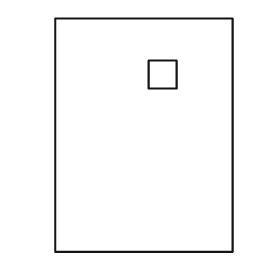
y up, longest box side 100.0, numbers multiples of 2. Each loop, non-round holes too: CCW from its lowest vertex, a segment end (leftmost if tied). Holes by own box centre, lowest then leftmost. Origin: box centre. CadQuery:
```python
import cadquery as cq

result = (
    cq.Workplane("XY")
    .moveTo(-38.0, -50.0)
    .lineTo(38.0, -50.0)
    .lineTo(38.0, 50.0)
    .lineTo(-38.0, 50.0)
    .close()
    .moveTo(2.0, 20.0)
    .lineTo(14.0, 20.0)
    .lineTo(14.0, 32.0)
    .lineTo(2.0, 32.0)
    .close()
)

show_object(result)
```